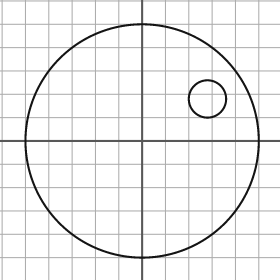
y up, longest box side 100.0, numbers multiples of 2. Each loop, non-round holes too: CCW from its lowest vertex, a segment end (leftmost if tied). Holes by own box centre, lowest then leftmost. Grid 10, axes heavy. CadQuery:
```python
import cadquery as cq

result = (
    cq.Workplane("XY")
    .moveTo(0.0, 0.0)
    .circle(50.0)
    .moveTo(28.0, 18.0)
    .circle(8.0)
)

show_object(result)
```